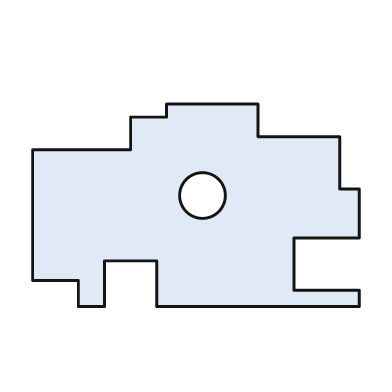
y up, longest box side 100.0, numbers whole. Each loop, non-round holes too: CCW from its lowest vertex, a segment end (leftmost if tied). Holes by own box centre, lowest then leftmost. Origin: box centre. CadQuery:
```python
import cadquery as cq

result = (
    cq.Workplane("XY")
    .moveTo(-36.0, -31.0)
    .lineTo(-28.0, -31.0)
    .lineTo(-28.0, -17.0)
    .lineTo(-12.0, -17.0)
    .lineTo(-12.0, -31.0)
    .lineTo(50.0, -31.0)
    .lineTo(50.0, -26.0)
    .lineTo(30.0, -26.0)
    .lineTo(30.0, -10.0)
    .lineTo(50.0, -10.0)
    .lineTo(50.0, 5.0)
    .lineTo(44.0, 5.0)
    .lineTo(44.0, 21.0)
    .lineTo(19.0, 21.0)
    .lineTo(19.0, 31.0)
    .lineTo(-9.0, 31.0)
    .lineTo(-9.0, 27.0)
    .lineTo(-20.0, 27.0)
    .lineTo(-20.0, 17.0)
    .lineTo(-50.0, 17.0)
    .lineTo(-50.0, -23.0)
    .lineTo(-36.0, -23.0)
    .close()
    .moveTo(2.0, 3.0)
    .circle(7.0)
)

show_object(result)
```